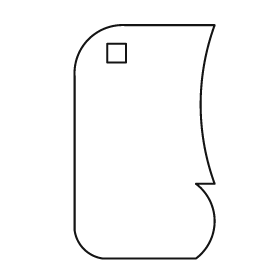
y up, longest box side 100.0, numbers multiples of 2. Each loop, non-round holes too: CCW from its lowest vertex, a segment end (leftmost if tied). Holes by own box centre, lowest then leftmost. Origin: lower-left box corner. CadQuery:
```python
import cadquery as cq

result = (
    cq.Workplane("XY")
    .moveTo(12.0, 0.0)
    .lineTo(52.0, 0.0)
    .threePointArc((60.0, 16.0), (52.0, 32.0))
    .lineTo(60.0, 32.0)
    .threePointArc((54.0, 66.0), (60.0, 100.0))
    .lineTo(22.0, 100.0)
    .threePointArc((6.0, 94.0), (0.0, 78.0))
    .lineTo(0.0, 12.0)
    .threePointArc((4.0, 4.0), (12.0, 0.0))
    .close()
    .moveTo(14.0, 84.0)
    .lineTo(22.0, 84.0)
    .lineTo(22.0, 92.0)
    .lineTo(14.0, 92.0)
    .close()
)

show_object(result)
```